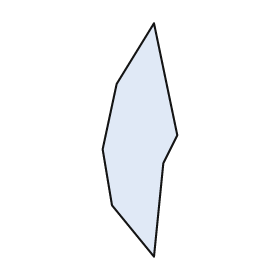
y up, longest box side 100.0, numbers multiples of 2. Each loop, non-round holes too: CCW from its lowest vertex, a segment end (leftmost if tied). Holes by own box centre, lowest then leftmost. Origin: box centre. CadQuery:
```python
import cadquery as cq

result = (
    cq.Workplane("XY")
    .moveTo(6.0, -50.0)
    .lineTo(10.0, -10.0)
    .lineTo(16.0, 2.0)
    .lineTo(6.0, 50.0)
    .lineTo(-10.0, 24.0)
    .lineTo(-16.0, -4.0)
    .lineTo(-12.0, -28.0)
    .close()
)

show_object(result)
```